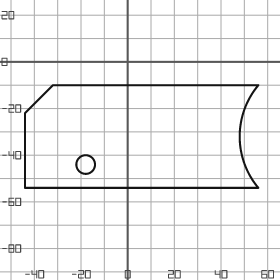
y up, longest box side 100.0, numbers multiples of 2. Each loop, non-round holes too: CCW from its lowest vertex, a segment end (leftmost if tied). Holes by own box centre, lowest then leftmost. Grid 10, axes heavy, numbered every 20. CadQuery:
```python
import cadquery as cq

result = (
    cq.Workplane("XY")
    .moveTo(-44.0, -54.0)
    .lineTo(56.0, -54.0)
    .threePointArc((48.0, -32.0), (56.0, -10.0))
    .lineTo(-32.0, -10.0)
    .lineTo(-44.0, -22.0)
    .close()
    .moveTo(-18.0, -44.0)
    .circle(4.0)
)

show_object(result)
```